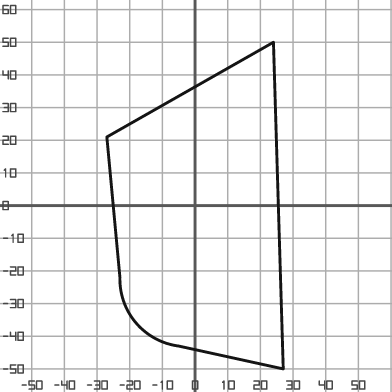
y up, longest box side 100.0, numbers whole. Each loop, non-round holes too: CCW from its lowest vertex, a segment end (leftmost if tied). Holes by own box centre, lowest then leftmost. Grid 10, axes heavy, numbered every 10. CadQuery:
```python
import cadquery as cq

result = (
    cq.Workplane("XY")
    .moveTo(27.0, -50.0)
    .lineTo(24.0, 50.0)
    .lineTo(-27.0, 21.0)
    .lineTo(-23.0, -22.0)
    .threePointArc((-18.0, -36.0), (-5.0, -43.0))
    .close()
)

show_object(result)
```